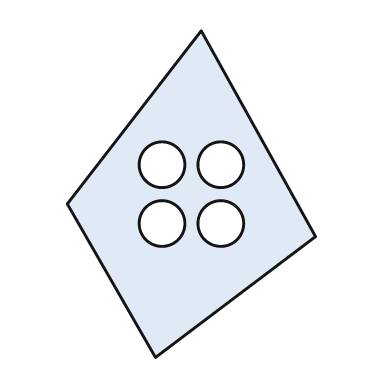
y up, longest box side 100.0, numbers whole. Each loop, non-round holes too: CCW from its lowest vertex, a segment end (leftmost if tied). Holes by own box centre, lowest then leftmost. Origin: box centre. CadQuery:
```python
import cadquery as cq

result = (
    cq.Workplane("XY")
    .moveTo(-11.0, -50.0)
    .lineTo(38.0, -13.0)
    .lineTo(3.0, 50.0)
    .lineTo(-38.0, -3.0)
    .close()
    .moveTo(-9.0, -9.0)
    .circle(7.0)
    .moveTo(9.0, -9.0)
    .circle(7.0)
    .moveTo(-9.0, 9.0)
    .circle(7.0)
    .moveTo(9.0, 9.0)
    .circle(7.0)
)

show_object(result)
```